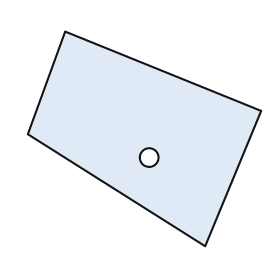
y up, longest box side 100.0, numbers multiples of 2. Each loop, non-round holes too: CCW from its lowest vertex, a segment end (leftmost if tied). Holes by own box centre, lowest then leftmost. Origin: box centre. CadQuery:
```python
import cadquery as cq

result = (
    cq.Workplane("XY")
    .moveTo(26.0, -46.0)
    .lineTo(50.0, 12.0)
    .lineTo(-34.0, 46.0)
    .lineTo(-50.0, 2.0)
    .close()
    .moveTo(2.0, -8.0)
    .circle(4.0)
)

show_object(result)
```